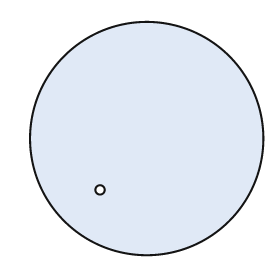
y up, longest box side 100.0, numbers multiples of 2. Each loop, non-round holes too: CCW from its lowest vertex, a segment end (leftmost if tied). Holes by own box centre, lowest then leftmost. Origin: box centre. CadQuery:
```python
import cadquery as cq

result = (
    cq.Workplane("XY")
    .moveTo(0.0, 0.0)
    .circle(50.0)
    .moveTo(-20.0, -22.0)
    .circle(2.0)
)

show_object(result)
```